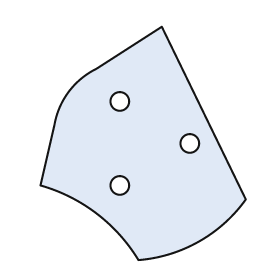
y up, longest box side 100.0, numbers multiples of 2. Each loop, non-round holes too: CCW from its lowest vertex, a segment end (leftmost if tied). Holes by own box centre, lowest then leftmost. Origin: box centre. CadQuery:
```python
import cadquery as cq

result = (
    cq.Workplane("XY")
    .moveTo(-2.0, -50.0)
    .threePointArc((24.0, -42.0), (44.0, -24.0))
    .lineTo(8.0, 50.0)
    .lineTo(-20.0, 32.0)
    .threePointArc((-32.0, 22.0), (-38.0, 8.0))
    .lineTo(-44.0, -18.0)
    .threePointArc((-20.0, -30.0), (-2.0, -50.0))
    .close()
    .moveTo(-10.0, -18.0)
    .circle(4.0)
    .moveTo(20.0, 0.0)
    .circle(4.0)
    .moveTo(-10.0, 18.0)
    .circle(4.0)
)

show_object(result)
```